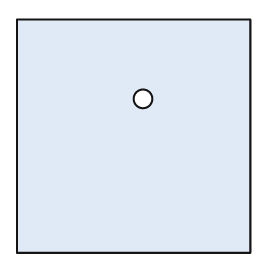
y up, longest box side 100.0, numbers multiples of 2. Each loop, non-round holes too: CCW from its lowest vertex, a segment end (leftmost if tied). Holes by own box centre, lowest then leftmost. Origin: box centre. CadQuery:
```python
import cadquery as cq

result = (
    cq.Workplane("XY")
    .moveTo(-50.0, -50.0)
    .lineTo(50.0, -50.0)
    .lineTo(50.0, 50.0)
    .lineTo(-50.0, 50.0)
    .close()
    .moveTo(4.0, 16.0)
    .circle(4.0)
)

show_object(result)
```